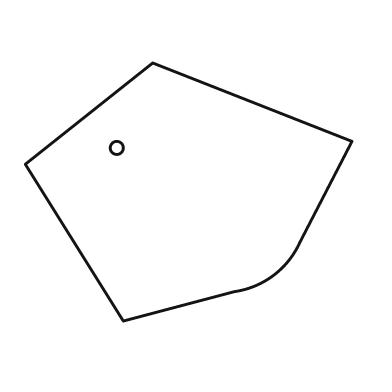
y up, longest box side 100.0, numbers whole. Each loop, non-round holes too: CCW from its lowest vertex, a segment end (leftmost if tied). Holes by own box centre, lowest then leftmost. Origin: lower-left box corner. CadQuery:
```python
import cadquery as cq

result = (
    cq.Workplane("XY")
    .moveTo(30.0, 0.0)
    .lineTo(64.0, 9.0)
    .threePointArc((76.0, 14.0), (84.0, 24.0))
    .lineTo(100.0, 55.0)
    .lineTo(39.0, 79.0)
    .lineTo(0.0, 48.0)
    .close()
    .moveTo(28.0, 53.0)
    .circle(2.0)
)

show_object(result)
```